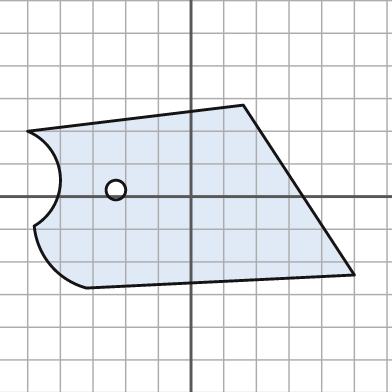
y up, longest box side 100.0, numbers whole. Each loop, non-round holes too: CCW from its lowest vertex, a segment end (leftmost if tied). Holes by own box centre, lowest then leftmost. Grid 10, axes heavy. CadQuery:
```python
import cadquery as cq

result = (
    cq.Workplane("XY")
    .moveTo(-32.0, -28.0)
    .lineTo(50.0, -24.0)
    .lineTo(16.0, 28.0)
    .lineTo(-50.0, 20.0)
    .threePointArc((-40.0, 6.0), (-48.0, -9.0))
    .threePointArc((-43.0, -21.0), (-32.0, -28.0))
    .close()
    .moveTo(-23.0, 2.0)
    .circle(3.0)
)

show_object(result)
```